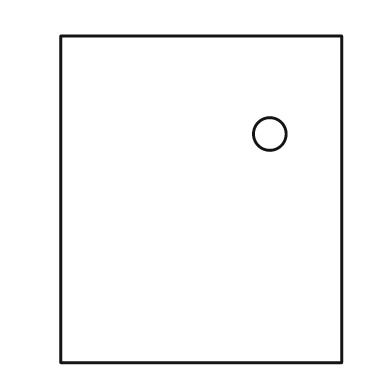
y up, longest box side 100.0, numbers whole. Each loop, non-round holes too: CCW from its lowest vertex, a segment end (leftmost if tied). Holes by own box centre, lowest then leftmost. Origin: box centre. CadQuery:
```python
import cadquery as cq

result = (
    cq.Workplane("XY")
    .moveTo(-43.0, -50.0)
    .lineTo(43.0, -50.0)
    .lineTo(43.0, 50.0)
    .lineTo(-43.0, 50.0)
    .close()
    .moveTo(21.0, 20.0)
    .circle(5.0)
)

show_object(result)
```